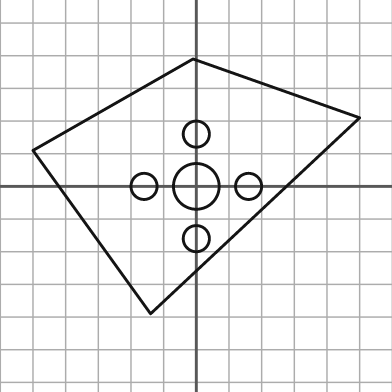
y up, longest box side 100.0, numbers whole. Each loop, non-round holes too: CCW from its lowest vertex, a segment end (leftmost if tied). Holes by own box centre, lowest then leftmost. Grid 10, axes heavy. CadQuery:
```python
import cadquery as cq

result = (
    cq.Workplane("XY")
    .moveTo(-14.0, -39.0)
    .lineTo(50.0, 21.0)
    .lineTo(-1.0, 39.0)
    .lineTo(-50.0, 11.0)
    .close()
    .moveTo(0.0, -16.0)
    .circle(4.0)
    .moveTo(-16.0, 0.0)
    .circle(4.0)
    .moveTo(0.0, 0.0)
    .circle(7.0)
    .moveTo(16.0, 0.0)
    .circle(4.0)
    .moveTo(0.0, 16.0)
    .circle(4.0)
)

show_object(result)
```